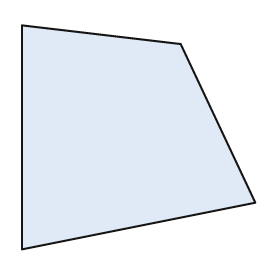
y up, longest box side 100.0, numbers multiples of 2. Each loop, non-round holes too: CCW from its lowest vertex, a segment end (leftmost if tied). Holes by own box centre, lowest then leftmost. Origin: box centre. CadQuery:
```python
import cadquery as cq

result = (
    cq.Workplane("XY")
    .moveTo(-50.0, -48.0)
    .lineTo(50.0, -28.0)
    .lineTo(18.0, 40.0)
    .lineTo(-50.0, 48.0)
    .close()
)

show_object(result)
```